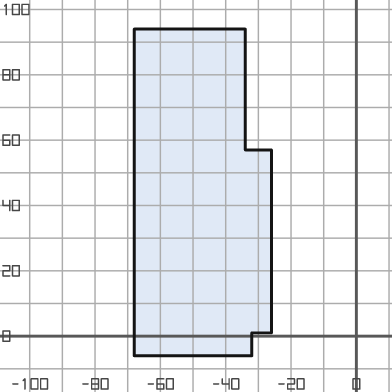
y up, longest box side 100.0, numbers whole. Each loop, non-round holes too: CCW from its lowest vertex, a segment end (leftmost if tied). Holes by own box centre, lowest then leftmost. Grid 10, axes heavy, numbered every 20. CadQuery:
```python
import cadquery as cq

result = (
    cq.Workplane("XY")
    .moveTo(-68.0, -6.0)
    .lineTo(-32.0, -6.0)
    .lineTo(-32.0, 1.0)
    .lineTo(-26.0, 1.0)
    .lineTo(-26.0, 57.0)
    .lineTo(-34.0, 57.0)
    .lineTo(-34.0, 94.0)
    .lineTo(-68.0, 94.0)
    .close()
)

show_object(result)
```